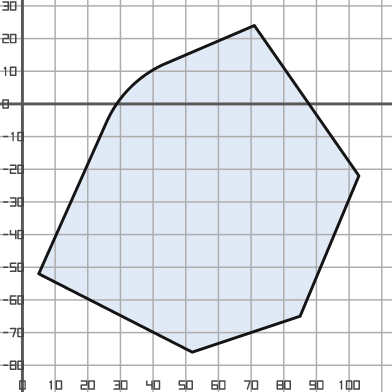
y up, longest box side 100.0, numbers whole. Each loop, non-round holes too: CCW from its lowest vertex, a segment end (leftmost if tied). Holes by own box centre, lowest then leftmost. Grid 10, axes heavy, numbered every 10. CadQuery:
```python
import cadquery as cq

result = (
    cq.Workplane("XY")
    .moveTo(52.0, -76.0)
    .lineTo(85.0, -65.0)
    .lineTo(103.0, -22.0)
    .lineTo(71.0, 24.0)
    .lineTo(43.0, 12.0)
    .threePointArc((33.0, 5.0), (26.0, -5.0))
    .lineTo(5.0, -52.0)
    .close()
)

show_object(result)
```